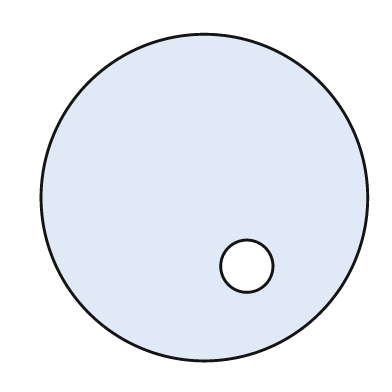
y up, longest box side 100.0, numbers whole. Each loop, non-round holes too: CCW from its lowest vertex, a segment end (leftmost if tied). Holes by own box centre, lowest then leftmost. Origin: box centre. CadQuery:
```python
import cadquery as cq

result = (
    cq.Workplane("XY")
    .moveTo(0.0, 0.0)
    .circle(50.0)
    .moveTo(13.0, -21.0)
    .circle(8.0)
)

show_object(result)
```